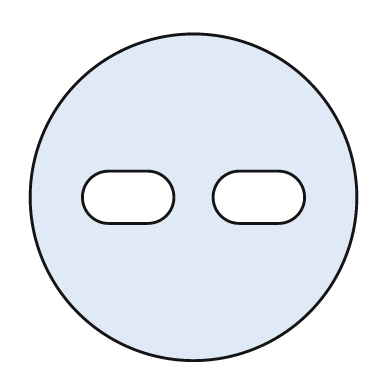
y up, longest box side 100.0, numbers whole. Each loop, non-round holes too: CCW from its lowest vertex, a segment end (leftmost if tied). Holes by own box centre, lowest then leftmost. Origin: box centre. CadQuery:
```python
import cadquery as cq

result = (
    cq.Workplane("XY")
    .moveTo(0.0, 0.0)
    .circle(50.0)
    .moveTo(-26.0, -8.0)
    .lineTo(-14.0, -8.0)
    .threePointArc((-6.0, 0.0), (-14.0, 8.0))
    .lineTo(-26.0, 8.0)
    .threePointArc((-34.0, 0.0), (-26.0, -8.0))
    .close()
    .moveTo(14.0, -8.0)
    .lineTo(26.0, -8.0)
    .threePointArc((34.0, 0.0), (26.0, 8.0))
    .lineTo(14.0, 8.0)
    .threePointArc((6.0, 0.0), (14.0, -8.0))
    .close()
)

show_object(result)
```